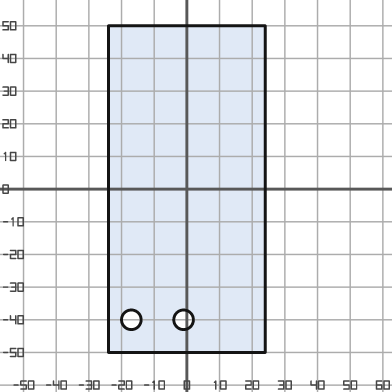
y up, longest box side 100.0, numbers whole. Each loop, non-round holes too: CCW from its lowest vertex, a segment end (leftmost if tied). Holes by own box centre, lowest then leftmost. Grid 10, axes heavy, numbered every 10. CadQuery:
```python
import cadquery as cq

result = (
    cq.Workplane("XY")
    .moveTo(-24.0, -50.0)
    .lineTo(24.0, -50.0)
    .lineTo(24.0, 50.0)
    .lineTo(-24.0, 50.0)
    .close()
    .moveTo(-17.0, -40.0)
    .circle(3.0)
    .moveTo(-1.0, -40.0)
    .circle(3.0)
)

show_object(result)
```